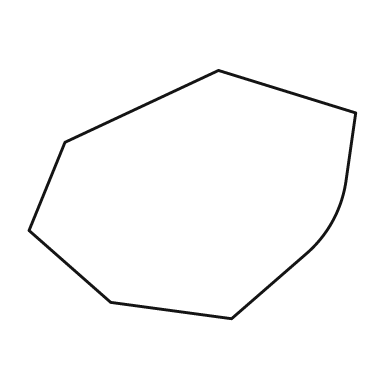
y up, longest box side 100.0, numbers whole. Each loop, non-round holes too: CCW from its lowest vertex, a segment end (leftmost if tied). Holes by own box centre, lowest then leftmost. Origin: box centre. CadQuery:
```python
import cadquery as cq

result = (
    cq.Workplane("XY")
    .moveTo(12.0, -38.0)
    .lineTo(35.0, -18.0)
    .threePointArc((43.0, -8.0), (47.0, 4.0))
    .lineTo(50.0, 25.0)
    .lineTo(8.0, 38.0)
    .lineTo(-39.0, 16.0)
    .lineTo(-50.0, -11.0)
    .lineTo(-25.0, -33.0)
    .close()
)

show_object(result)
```